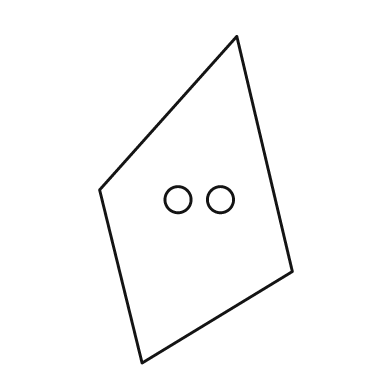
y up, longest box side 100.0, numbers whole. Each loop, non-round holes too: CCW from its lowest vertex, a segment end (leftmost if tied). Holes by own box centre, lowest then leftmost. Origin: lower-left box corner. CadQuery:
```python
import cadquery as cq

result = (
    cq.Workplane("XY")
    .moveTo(13.0, 0.0)
    .lineTo(59.0, 28.0)
    .lineTo(42.0, 100.0)
    .lineTo(0.0, 53.0)
    .close()
    .moveTo(24.0, 50.0)
    .circle(4.0)
    .moveTo(37.0, 50.0)
    .circle(4.0)
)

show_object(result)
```